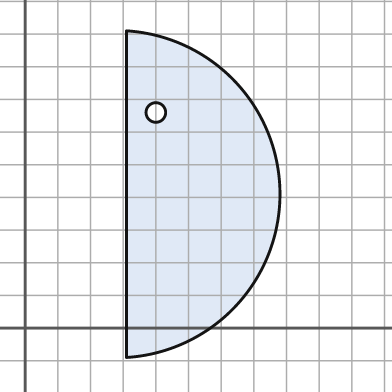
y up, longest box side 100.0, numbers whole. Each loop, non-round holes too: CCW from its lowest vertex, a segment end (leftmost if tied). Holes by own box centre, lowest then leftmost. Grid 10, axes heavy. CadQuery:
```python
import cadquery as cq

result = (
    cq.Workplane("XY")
    .moveTo(31.0, -9.0)
    .threePointArc((78.0, 41.0), (31.0, 91.0))
    .close()
    .moveTo(40.0, 66.0)
    .circle(3.0)
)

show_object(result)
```